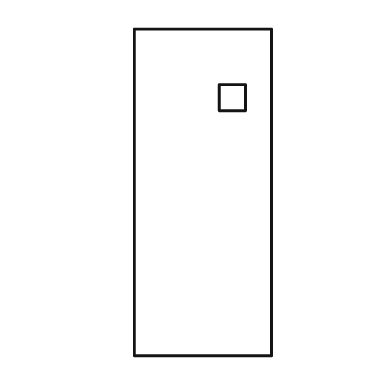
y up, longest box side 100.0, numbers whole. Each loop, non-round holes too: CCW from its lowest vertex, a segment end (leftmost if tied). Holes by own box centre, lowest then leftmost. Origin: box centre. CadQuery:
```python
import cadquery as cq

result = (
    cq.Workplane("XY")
    .moveTo(-21.0, -50.0)
    .lineTo(21.0, -50.0)
    .lineTo(21.0, 50.0)
    .lineTo(-21.0, 50.0)
    .close()
    .moveTo(5.0, 25.0)
    .lineTo(13.0, 25.0)
    .lineTo(13.0, 33.0)
    .lineTo(5.0, 33.0)
    .close()
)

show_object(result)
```